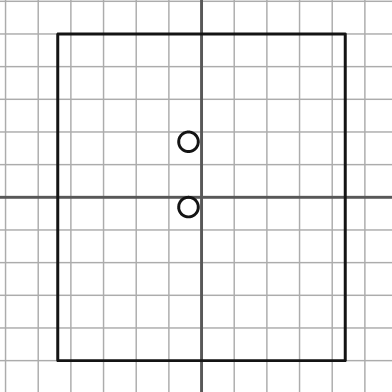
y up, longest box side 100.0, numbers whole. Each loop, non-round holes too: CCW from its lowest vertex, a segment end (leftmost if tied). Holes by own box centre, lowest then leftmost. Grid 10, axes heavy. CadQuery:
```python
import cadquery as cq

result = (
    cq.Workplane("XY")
    .moveTo(-44.0, -50.0)
    .lineTo(44.0, -50.0)
    .lineTo(44.0, 50.0)
    .lineTo(-44.0, 50.0)
    .close()
    .moveTo(-4.0, -3.0)
    .circle(3.0)
    .moveTo(-4.0, 17.0)
    .circle(3.0)
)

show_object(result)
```